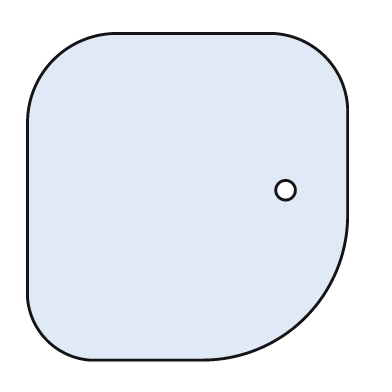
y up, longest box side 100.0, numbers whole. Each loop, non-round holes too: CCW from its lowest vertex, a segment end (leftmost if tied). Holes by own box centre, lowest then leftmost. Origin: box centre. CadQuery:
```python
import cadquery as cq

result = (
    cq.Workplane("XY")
    .moveTo(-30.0, -50.0)
    .lineTo(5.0, -50.0)
    .threePointArc((36.0, -37.0), (49.0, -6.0))
    .lineTo(49.0, 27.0)
    .threePointArc((42.0, 43.0), (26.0, 50.0))
    .lineTo(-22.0, 50.0)
    .threePointArc((-41.0, 42.0), (-49.0, 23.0))
    .lineTo(-49.0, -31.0)
    .threePointArc((-43.0, -44.0), (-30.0, -50.0))
    .close()
    .moveTo(30.0, 2.0)
    .circle(3.0)
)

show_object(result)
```